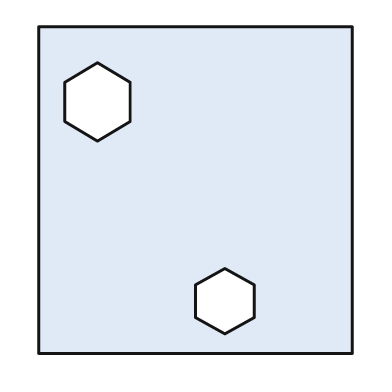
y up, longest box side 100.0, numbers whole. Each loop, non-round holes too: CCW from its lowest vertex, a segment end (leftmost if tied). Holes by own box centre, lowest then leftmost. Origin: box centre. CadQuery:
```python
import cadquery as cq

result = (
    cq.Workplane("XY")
    .moveTo(-48.0, -50.0)
    .lineTo(48.0, -50.0)
    .lineTo(48.0, 50.0)
    .lineTo(-48.0, 50.0)
    .close()
    .moveTo(9.0, -44.0)
    .lineTo(18.0, -39.0)
    .lineTo(18.0, -29.0)
    .lineTo(9.0, -24.0)
    .lineTo(0.0, -29.0)
    .lineTo(0.0, -39.0)
    .close()
    .moveTo(-30.0, 15.0)
    .lineTo(-20.0, 21.0)
    .lineTo(-20.0, 33.0)
    .lineTo(-30.0, 39.0)
    .lineTo(-40.0, 33.0)
    .lineTo(-40.0, 21.0)
    .close()
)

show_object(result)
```